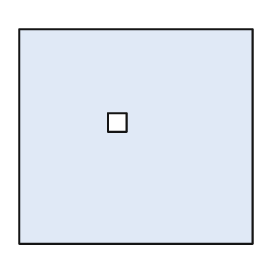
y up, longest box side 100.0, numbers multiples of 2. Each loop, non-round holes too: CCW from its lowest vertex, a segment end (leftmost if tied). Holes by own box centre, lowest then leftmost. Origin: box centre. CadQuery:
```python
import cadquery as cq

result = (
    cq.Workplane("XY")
    .moveTo(-50.0, -46.0)
    .lineTo(50.0, -46.0)
    .lineTo(50.0, 46.0)
    .lineTo(-50.0, 46.0)
    .close()
    .moveTo(-12.0, 2.0)
    .lineTo(-4.0, 2.0)
    .lineTo(-4.0, 10.0)
    .lineTo(-12.0, 10.0)
    .close()
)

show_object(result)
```